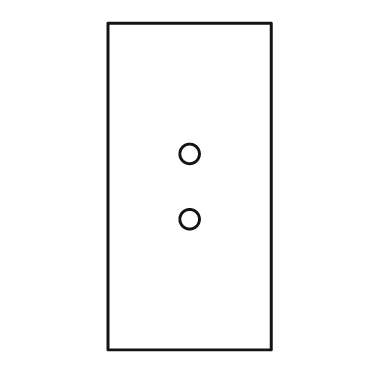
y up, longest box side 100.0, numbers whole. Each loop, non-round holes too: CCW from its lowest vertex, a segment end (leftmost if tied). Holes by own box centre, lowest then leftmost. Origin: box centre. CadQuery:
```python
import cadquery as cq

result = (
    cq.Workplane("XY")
    .moveTo(-25.0, -50.0)
    .lineTo(25.0, -50.0)
    .lineTo(25.0, 50.0)
    .lineTo(-25.0, 50.0)
    .close()
    .moveTo(0.0, -10.0)
    .circle(3.0)
    .moveTo(0.0, 10.0)
    .circle(3.0)
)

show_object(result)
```